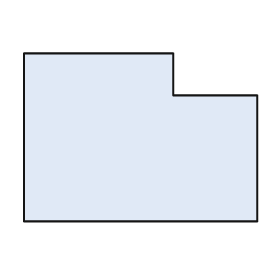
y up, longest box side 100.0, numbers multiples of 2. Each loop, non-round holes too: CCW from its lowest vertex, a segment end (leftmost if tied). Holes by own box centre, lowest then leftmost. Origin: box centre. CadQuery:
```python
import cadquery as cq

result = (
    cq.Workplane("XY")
    .moveTo(-50.0, -36.0)
    .lineTo(50.0, -36.0)
    .lineTo(50.0, 18.0)
    .lineTo(14.0, 18.0)
    .lineTo(14.0, 36.0)
    .lineTo(-50.0, 36.0)
    .close()
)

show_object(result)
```